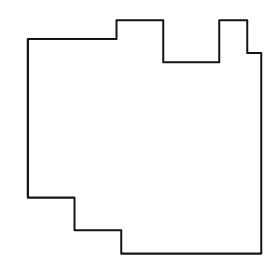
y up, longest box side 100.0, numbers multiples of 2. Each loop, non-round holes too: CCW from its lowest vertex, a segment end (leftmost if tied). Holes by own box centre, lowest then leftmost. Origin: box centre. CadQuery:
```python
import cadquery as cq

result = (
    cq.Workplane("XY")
    .moveTo(-10.0, -50.0)
    .lineTo(50.0, -50.0)
    .lineTo(50.0, 36.0)
    .lineTo(44.0, 36.0)
    .lineTo(44.0, 50.0)
    .lineTo(32.0, 50.0)
    .lineTo(32.0, 32.0)
    .lineTo(8.0, 32.0)
    .lineTo(8.0, 50.0)
    .lineTo(-12.0, 50.0)
    .lineTo(-12.0, 42.0)
    .lineTo(-50.0, 42.0)
    .lineTo(-50.0, -26.0)
    .lineTo(-30.0, -26.0)
    .lineTo(-30.0, -40.0)
    .lineTo(-10.0, -40.0)
    .close()
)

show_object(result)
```